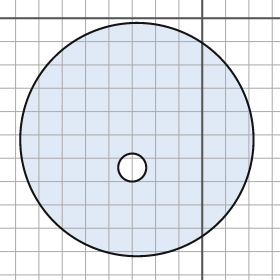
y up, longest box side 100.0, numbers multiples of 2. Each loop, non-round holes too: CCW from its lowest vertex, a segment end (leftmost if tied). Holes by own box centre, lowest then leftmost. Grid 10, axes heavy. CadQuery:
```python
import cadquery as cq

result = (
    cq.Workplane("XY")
    .moveTo(-28.0, -52.0)
    .circle(50.0)
    .moveTo(-30.0, -64.0)
    .circle(6.0)
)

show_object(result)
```